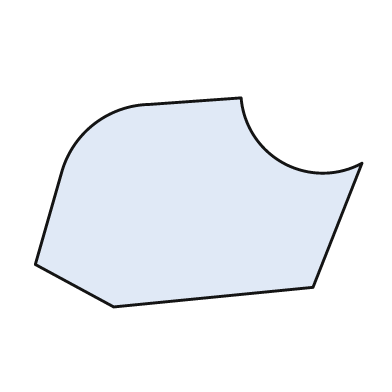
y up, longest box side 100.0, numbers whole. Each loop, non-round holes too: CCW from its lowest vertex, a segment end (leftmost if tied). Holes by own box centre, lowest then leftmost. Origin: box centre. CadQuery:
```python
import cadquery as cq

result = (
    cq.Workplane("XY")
    .moveTo(-26.0, -32.0)
    .lineTo(35.0, -26.0)
    .lineTo(50.0, 12.0)
    .threePointArc((26.0, 12.0), (13.0, 32.0))
    .lineTo(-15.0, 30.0)
    .threePointArc((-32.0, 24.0), (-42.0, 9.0))
    .lineTo(-50.0, -19.0)
    .close()
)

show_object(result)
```